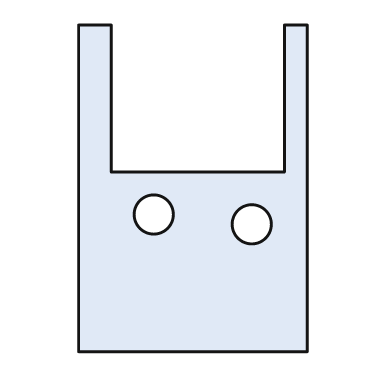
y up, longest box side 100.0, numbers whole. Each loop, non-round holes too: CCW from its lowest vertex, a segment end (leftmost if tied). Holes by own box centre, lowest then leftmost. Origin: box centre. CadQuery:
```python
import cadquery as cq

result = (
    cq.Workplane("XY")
    .moveTo(-35.0, -50.0)
    .lineTo(35.0, -50.0)
    .lineTo(35.0, 50.0)
    .lineTo(28.0, 50.0)
    .lineTo(28.0, 5.0)
    .lineTo(-25.0, 5.0)
    .lineTo(-25.0, 50.0)
    .lineTo(-35.0, 50.0)
    .close()
    .moveTo(18.0, -11.0)
    .circle(6.0)
    .moveTo(-12.0, -8.0)
    .circle(6.0)
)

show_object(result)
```